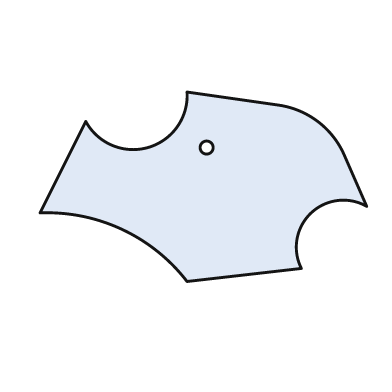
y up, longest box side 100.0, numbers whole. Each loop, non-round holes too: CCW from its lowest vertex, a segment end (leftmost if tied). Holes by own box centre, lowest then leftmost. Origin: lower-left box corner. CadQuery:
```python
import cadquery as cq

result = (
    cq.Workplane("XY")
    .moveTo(45.0, 0.0)
    .lineTo(80.0, 4.0)
    .threePointArc((83.0, 21.0), (100.0, 23.0))
    .lineTo(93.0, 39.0)
    .threePointArc((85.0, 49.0), (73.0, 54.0))
    .lineTo(45.0, 58.0)
    .threePointArc((33.0, 41.0), (14.0, 49.0))
    .lineTo(0.0, 21.0)
    .threePointArc((25.0, 16.0), (45.0, 0.0))
    .close()
    .moveTo(51.0, 41.0)
    .circle(2.0)
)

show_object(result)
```